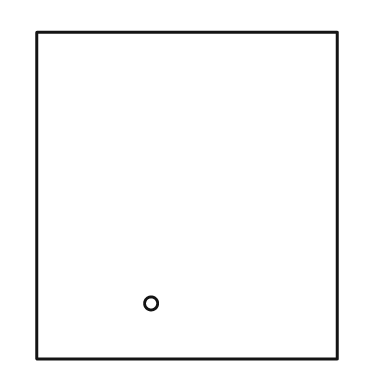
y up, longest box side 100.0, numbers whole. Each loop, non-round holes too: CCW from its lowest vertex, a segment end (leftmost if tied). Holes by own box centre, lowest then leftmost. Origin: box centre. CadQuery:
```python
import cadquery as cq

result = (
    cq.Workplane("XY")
    .moveTo(-46.0, -50.0)
    .lineTo(46.0, -50.0)
    .lineTo(46.0, 50.0)
    .lineTo(-46.0, 50.0)
    .close()
    .moveTo(-11.0, -33.0)
    .circle(2.0)
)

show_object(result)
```